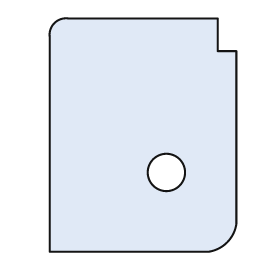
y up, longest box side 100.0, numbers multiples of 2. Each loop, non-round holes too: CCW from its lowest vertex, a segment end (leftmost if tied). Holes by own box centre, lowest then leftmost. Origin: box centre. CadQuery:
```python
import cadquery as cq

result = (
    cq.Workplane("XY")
    .moveTo(-40.0, -50.0)
    .lineTo(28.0, -50.0)
    .threePointArc((36.0, -46.0), (40.0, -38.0))
    .lineTo(40.0, 36.0)
    .lineTo(32.0, 36.0)
    .lineTo(32.0, 50.0)
    .lineTo(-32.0, 50.0)
    .threePointArc((-38.0, 48.0), (-40.0, 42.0))
    .close()
    .moveTo(10.0, -16.0)
    .circle(8.0)
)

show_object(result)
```